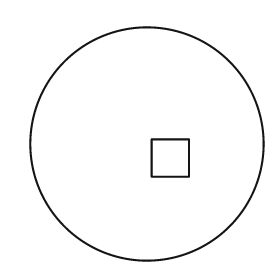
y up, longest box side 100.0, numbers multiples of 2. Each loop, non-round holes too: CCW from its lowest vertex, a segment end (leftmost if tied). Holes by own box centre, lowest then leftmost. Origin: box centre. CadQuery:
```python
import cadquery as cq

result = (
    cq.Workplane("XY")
    .moveTo(0.0, 0.0)
    .circle(50.0)
    .moveTo(2.0, -14.0)
    .lineTo(18.0, -14.0)
    .lineTo(18.0, 2.0)
    .lineTo(2.0, 2.0)
    .close()
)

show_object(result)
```